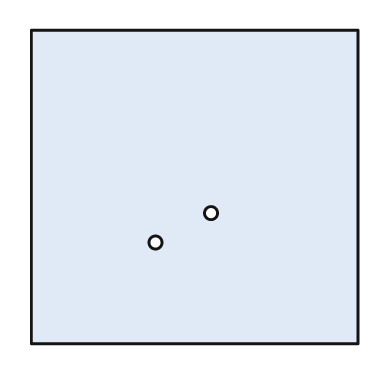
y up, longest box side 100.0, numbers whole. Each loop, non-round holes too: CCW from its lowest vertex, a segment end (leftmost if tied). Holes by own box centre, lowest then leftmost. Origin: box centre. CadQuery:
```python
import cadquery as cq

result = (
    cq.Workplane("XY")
    .moveTo(-50.0, -48.0)
    .lineTo(50.0, -48.0)
    .lineTo(50.0, 48.0)
    .lineTo(-50.0, 48.0)
    .close()
    .moveTo(-12.0, -17.0)
    .circle(2.0)
    .moveTo(5.0, -8.0)
    .circle(2.0)
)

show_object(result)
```